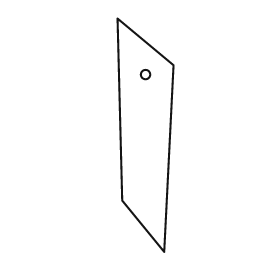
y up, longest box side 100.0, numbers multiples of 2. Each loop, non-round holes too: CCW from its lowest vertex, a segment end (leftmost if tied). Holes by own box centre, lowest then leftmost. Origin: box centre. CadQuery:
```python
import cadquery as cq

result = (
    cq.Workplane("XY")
    .moveTo(8.0, -50.0)
    .lineTo(12.0, 30.0)
    .lineTo(-12.0, 50.0)
    .lineTo(-10.0, -28.0)
    .close()
    .moveTo(0.0, 26.0)
    .circle(2.0)
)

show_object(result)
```